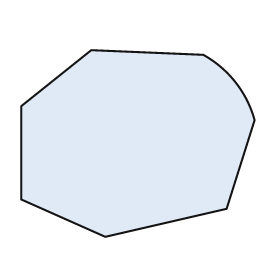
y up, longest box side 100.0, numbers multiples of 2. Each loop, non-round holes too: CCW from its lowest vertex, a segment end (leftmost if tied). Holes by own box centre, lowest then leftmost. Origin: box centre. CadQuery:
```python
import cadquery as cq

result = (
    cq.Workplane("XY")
    .moveTo(-14.0, -40.0)
    .lineTo(38.0, -28.0)
    .lineTo(50.0, 10.0)
    .threePointArc((42.0, 26.0), (28.0, 38.0))
    .lineTo(-20.0, 40.0)
    .lineTo(-50.0, 16.0)
    .lineTo(-50.0, -24.0)
    .close()
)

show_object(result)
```